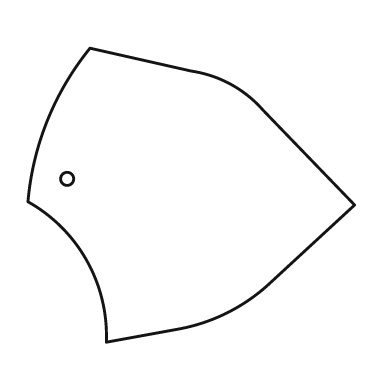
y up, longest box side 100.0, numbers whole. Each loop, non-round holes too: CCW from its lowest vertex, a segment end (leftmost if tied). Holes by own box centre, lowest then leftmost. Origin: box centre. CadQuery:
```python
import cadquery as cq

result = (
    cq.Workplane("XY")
    .moveTo(-26.0, -45.0)
    .lineTo(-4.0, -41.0)
    .threePointArc((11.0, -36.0), (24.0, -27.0))
    .lineTo(50.0, -3.0)
    .lineTo(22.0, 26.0)
    .threePointArc((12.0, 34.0), (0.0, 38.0))
    .lineTo(-31.0, 45.0)
    .threePointArc((-44.0, 23.0), (-50.0, -2.0))
    .threePointArc((-32.0, -20.0), (-26.0, -45.0))
    .close()
    .moveTo(-38.0, 5.0)
    .circle(2.0)
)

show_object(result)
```